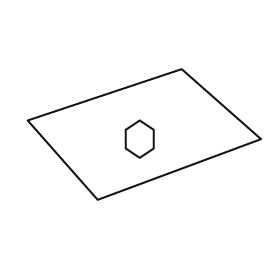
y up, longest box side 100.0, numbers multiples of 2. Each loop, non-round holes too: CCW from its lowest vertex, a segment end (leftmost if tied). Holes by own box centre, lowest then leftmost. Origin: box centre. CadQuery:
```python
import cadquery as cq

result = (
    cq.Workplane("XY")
    .moveTo(-20.0, -28.0)
    .lineTo(50.0, -2.0)
    .lineTo(16.0, 28.0)
    .lineTo(-50.0, 6.0)
    .close()
    .moveTo(-2.0, -10.0)
    .lineTo(4.0, -6.0)
    .lineTo(4.0, 2.0)
    .lineTo(-2.0, 6.0)
    .lineTo(-8.0, 2.0)
    .lineTo(-8.0, -6.0)
    .close()
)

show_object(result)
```